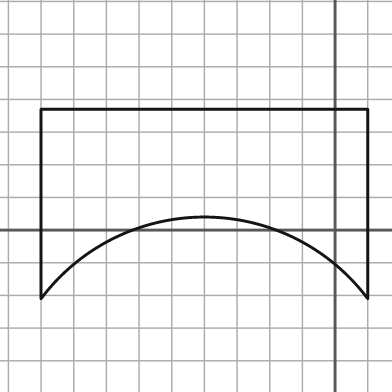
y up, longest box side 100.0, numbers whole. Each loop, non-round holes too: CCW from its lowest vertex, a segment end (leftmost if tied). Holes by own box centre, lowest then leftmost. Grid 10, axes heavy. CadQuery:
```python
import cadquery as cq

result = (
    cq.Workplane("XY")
    .moveTo(-90.0, -21.0)
    .threePointArc((-40.0, 4.0), (10.0, -21.0))
    .lineTo(10.0, 37.0)
    .lineTo(-90.0, 37.0)
    .close()
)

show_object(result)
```